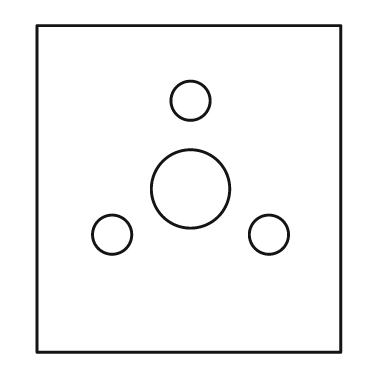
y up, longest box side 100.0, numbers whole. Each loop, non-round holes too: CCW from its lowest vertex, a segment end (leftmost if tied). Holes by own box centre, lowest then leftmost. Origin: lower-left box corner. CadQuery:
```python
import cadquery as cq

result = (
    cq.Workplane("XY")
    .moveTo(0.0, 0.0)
    .lineTo(93.0, 0.0)
    .lineTo(93.0, 100.0)
    .lineTo(0.0, 100.0)
    .close()
    .moveTo(23.0, 36.0)
    .circle(6.0)
    .moveTo(71.0, 36.0)
    .circle(6.0)
    .moveTo(47.0, 50.0)
    .circle(12.0)
    .moveTo(47.0, 77.0)
    .circle(6.0)
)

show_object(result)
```